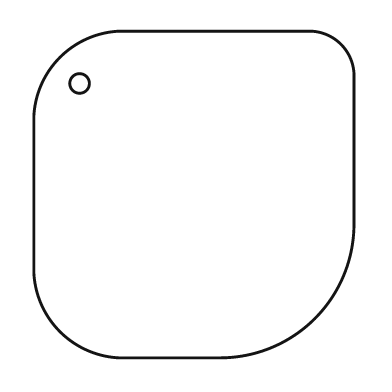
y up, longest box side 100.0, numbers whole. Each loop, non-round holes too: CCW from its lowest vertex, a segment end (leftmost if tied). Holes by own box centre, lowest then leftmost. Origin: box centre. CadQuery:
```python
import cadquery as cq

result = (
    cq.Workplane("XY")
    .moveTo(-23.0, -50.0)
    .lineTo(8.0, -50.0)
    .threePointArc((37.0, -38.0), (49.0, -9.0))
    .lineTo(49.0, 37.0)
    .threePointArc((45.0, 46.0), (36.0, 50.0))
    .lineTo(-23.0, 50.0)
    .threePointArc((-41.0, 42.0), (-49.0, 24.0))
    .lineTo(-49.0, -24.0)
    .threePointArc((-41.0, -42.0), (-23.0, -50.0))
    .close()
    .moveTo(-35.0, 34.0)
    .circle(3.0)
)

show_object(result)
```